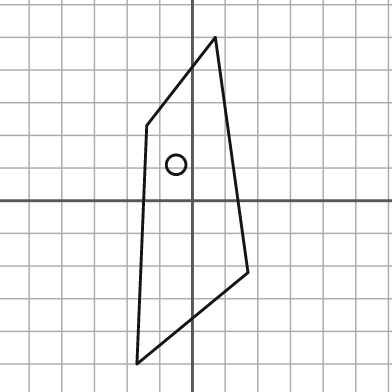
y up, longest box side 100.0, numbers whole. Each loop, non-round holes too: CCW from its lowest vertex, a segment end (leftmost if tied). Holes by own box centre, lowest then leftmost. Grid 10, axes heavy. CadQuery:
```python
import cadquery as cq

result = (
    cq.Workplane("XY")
    .moveTo(-17.0, -50.0)
    .lineTo(17.0, -22.0)
    .lineTo(7.0, 50.0)
    .lineTo(-14.0, 23.0)
    .close()
    .moveTo(-5.0, 11.0)
    .circle(3.0)
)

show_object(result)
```